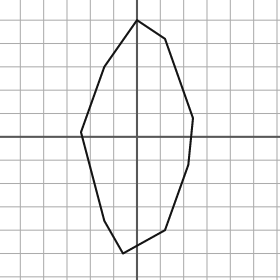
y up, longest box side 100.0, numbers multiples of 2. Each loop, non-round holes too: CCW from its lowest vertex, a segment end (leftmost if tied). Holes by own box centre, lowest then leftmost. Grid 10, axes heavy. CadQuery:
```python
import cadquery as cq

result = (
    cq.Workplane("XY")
    .moveTo(-6.0, -50.0)
    .lineTo(12.0, -40.0)
    .lineTo(22.0, -12.0)
    .lineTo(24.0, 8.0)
    .lineTo(12.0, 42.0)
    .lineTo(0.0, 50.0)
    .lineTo(-14.0, 30.0)
    .lineTo(-24.0, 2.0)
    .lineTo(-14.0, -36.0)
    .close()
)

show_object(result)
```